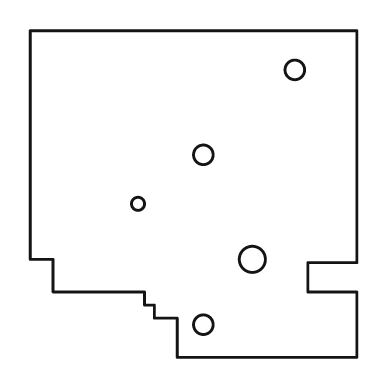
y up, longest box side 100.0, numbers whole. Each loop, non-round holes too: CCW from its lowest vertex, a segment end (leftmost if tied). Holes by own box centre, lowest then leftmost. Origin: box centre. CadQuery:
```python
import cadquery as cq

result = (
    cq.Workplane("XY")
    .moveTo(-5.0, -50.0)
    .lineTo(50.0, -50.0)
    .lineTo(50.0, -30.0)
    .lineTo(35.0, -30.0)
    .lineTo(35.0, -21.0)
    .lineTo(50.0, -21.0)
    .lineTo(50.0, 50.0)
    .lineTo(-50.0, 50.0)
    .lineTo(-50.0, -20.0)
    .lineTo(-43.0, -20.0)
    .lineTo(-43.0, -30.0)
    .lineTo(-15.0, -30.0)
    .lineTo(-15.0, -34.0)
    .lineTo(-12.0, -34.0)
    .lineTo(-12.0, -38.0)
    .lineTo(-5.0, -38.0)
    .close()
    .moveTo(3.0, -40.0)
    .circle(3.0)
    .moveTo(18.0, -20.0)
    .circle(4.0)
    .moveTo(-17.0, -3.0)
    .circle(2.0)
    .moveTo(3.0, 12.0)
    .circle(3.0)
    .moveTo(31.0, 38.0)
    .circle(3.0)
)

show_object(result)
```